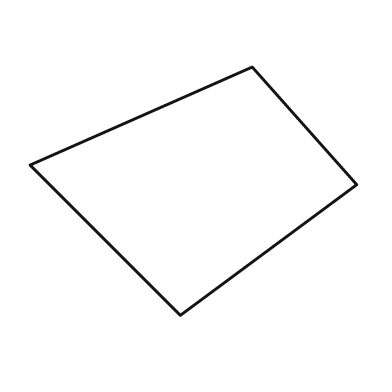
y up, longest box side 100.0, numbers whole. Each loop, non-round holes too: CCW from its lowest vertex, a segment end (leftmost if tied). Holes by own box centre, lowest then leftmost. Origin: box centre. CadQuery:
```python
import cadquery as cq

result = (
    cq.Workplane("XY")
    .moveTo(-4.0, -38.0)
    .lineTo(50.0, 2.0)
    .lineTo(18.0, 38.0)
    .lineTo(-50.0, 8.0)
    .close()
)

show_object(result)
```